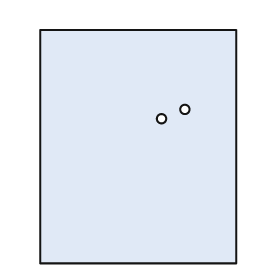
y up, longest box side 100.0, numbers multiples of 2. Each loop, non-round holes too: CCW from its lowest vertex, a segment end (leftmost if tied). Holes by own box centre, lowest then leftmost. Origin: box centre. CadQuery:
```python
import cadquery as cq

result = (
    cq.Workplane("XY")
    .moveTo(-42.0, -50.0)
    .lineTo(42.0, -50.0)
    .lineTo(42.0, 50.0)
    .lineTo(-42.0, 50.0)
    .close()
    .moveTo(10.0, 12.0)
    .circle(2.0)
    .moveTo(20.0, 16.0)
    .circle(2.0)
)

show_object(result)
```